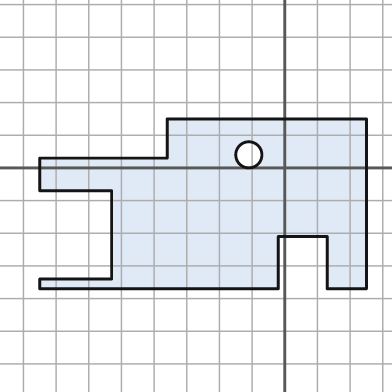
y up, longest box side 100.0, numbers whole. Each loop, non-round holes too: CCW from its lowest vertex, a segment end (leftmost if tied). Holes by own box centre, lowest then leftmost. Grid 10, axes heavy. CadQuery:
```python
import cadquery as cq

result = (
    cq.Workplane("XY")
    .moveTo(-75.0, -37.0)
    .lineTo(-2.0, -37.0)
    .lineTo(-2.0, -21.0)
    .lineTo(13.0, -21.0)
    .lineTo(13.0, -37.0)
    .lineTo(25.0, -37.0)
    .lineTo(25.0, 15.0)
    .lineTo(-36.0, 15.0)
    .lineTo(-36.0, 3.0)
    .lineTo(-75.0, 3.0)
    .lineTo(-75.0, -7.0)
    .lineTo(-53.0, -7.0)
    .lineTo(-53.0, -34.0)
    .lineTo(-75.0, -34.0)
    .close()
    .moveTo(-11.0, 4.0)
    .circle(4.0)
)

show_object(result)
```